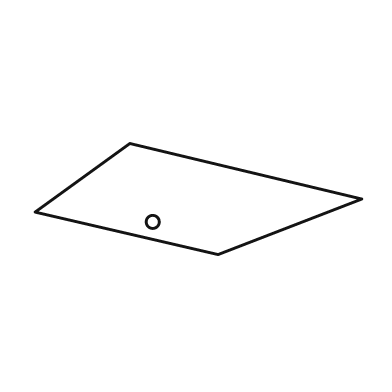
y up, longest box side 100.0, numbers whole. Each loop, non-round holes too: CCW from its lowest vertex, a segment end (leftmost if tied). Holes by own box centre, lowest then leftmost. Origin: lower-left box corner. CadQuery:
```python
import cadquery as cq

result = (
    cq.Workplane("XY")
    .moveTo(56.0, 0.0)
    .lineTo(100.0, 17.0)
    .lineTo(29.0, 34.0)
    .lineTo(0.0, 13.0)
    .close()
    .moveTo(36.0, 10.0)
    .circle(2.0)
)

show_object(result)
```